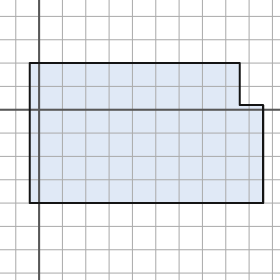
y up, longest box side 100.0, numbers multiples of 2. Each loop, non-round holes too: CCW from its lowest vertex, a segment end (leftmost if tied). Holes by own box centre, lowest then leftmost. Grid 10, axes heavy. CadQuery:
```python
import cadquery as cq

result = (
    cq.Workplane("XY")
    .moveTo(-4.0, -40.0)
    .lineTo(96.0, -40.0)
    .lineTo(96.0, 2.0)
    .lineTo(86.0, 2.0)
    .lineTo(86.0, 20.0)
    .lineTo(-4.0, 20.0)
    .close()
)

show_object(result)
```